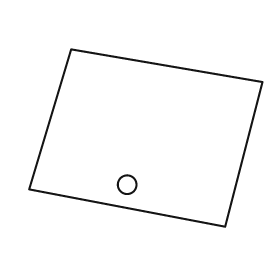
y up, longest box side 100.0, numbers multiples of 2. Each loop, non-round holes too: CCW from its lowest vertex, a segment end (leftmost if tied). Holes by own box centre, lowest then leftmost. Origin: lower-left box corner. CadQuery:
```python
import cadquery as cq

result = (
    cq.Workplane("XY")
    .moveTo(84.0, 0.0)
    .lineTo(100.0, 62.0)
    .lineTo(18.0, 76.0)
    .lineTo(0.0, 16.0)
    .close()
    .moveTo(42.0, 18.0)
    .circle(4.0)
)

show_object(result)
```